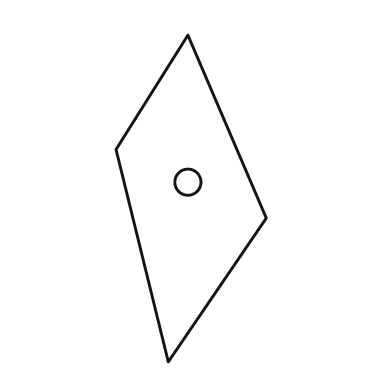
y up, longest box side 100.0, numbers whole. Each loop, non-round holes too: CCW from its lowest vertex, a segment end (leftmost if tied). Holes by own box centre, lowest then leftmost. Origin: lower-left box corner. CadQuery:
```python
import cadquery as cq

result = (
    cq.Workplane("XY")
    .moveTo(16.0, 0.0)
    .lineTo(46.0, 44.0)
    .lineTo(22.0, 100.0)
    .lineTo(0.0, 65.0)
    .close()
    .moveTo(22.0, 55.0)
    .circle(4.0)
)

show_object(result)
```